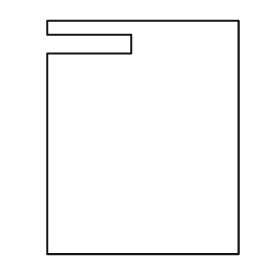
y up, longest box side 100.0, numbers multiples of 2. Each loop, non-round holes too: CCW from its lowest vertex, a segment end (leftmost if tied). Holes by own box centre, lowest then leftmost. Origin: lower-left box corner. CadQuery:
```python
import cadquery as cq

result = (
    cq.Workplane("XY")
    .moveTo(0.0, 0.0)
    .lineTo(82.0, 0.0)
    .lineTo(82.0, 100.0)
    .lineTo(0.0, 100.0)
    .lineTo(0.0, 94.0)
    .lineTo(36.0, 94.0)
    .lineTo(36.0, 86.0)
    .lineTo(0.0, 86.0)
    .close()
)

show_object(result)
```